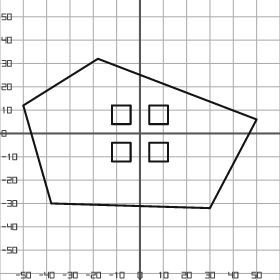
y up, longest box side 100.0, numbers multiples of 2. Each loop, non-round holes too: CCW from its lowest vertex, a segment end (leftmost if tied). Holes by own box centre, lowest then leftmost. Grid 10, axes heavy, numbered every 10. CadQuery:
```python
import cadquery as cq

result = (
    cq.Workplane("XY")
    .moveTo(30.0, -32.0)
    .lineTo(50.0, 6.0)
    .lineTo(-18.0, 32.0)
    .lineTo(-50.0, 12.0)
    .lineTo(-38.0, -30.0)
    .close()
    .moveTo(-12.0, -12.0)
    .lineTo(-4.0, -12.0)
    .lineTo(-4.0, -4.0)
    .lineTo(-12.0, -4.0)
    .close()
    .moveTo(4.0, -12.0)
    .lineTo(12.0, -12.0)
    .lineTo(12.0, -4.0)
    .lineTo(4.0, -4.0)
    .close()
    .moveTo(-12.0, 4.0)
    .lineTo(-4.0, 4.0)
    .lineTo(-4.0, 12.0)
    .lineTo(-12.0, 12.0)
    .close()
    .moveTo(4.0, 4.0)
    .lineTo(12.0, 4.0)
    .lineTo(12.0, 12.0)
    .lineTo(4.0, 12.0)
    .close()
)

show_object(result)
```